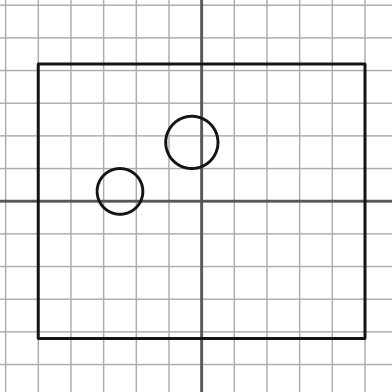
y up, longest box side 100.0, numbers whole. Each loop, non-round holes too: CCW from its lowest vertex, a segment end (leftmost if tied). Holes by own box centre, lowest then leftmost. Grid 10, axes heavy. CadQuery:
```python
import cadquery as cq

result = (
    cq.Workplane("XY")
    .moveTo(-50.0, -42.0)
    .lineTo(50.0, -42.0)
    .lineTo(50.0, 42.0)
    .lineTo(-50.0, 42.0)
    .close()
    .moveTo(-25.0, 3.0)
    .circle(7.0)
    .moveTo(-3.0, 18.0)
    .circle(8.0)
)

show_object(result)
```